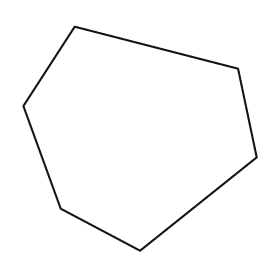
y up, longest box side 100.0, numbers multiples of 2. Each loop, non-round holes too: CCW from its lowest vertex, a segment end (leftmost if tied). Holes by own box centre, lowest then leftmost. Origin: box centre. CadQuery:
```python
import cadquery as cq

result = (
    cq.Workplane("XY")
    .moveTo(0.0, -48.0)
    .lineTo(50.0, -8.0)
    .lineTo(42.0, 30.0)
    .lineTo(-28.0, 48.0)
    .lineTo(-50.0, 14.0)
    .lineTo(-34.0, -30.0)
    .close()
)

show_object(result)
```